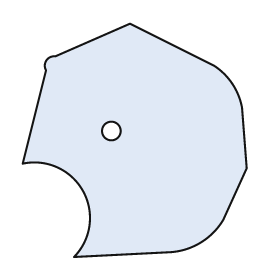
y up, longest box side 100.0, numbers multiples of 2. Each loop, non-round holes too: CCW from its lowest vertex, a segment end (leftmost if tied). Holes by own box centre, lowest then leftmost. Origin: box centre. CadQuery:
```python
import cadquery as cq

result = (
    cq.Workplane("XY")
    .moveTo(-26.0, -50.0)
    .lineTo(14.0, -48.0)
    .threePointArc((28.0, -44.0), (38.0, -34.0))
    .lineTo(48.0, -12.0)
    .lineTo(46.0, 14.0)
    .threePointArc((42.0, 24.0), (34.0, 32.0))
    .lineTo(-2.0, 50.0)
    .lineTo(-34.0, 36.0)
    .threePointArc((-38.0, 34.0), (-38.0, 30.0))
    .lineTo(-48.0, -10.0)
    .threePointArc((-22.0, -22.0), (-26.0, -50.0))
    .close()
    .moveTo(-10.0, 4.0)
    .circle(4.0)
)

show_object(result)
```